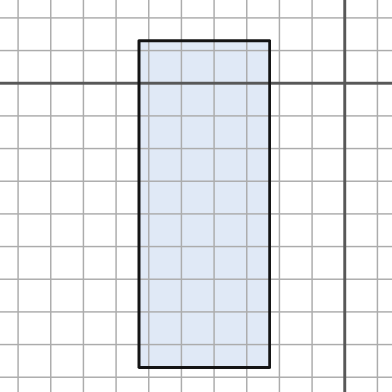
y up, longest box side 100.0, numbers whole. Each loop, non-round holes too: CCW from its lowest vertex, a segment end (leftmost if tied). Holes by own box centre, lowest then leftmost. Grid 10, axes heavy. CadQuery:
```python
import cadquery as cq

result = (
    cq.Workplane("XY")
    .moveTo(-63.0, -87.0)
    .lineTo(-23.0, -87.0)
    .lineTo(-23.0, 13.0)
    .lineTo(-63.0, 13.0)
    .close()
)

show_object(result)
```